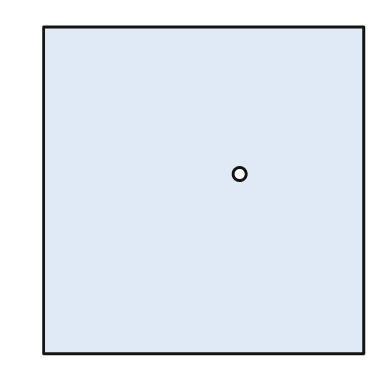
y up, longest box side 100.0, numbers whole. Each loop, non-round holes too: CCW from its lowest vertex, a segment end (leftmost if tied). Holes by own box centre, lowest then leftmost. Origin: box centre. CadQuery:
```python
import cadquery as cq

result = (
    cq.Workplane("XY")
    .moveTo(-49.0, -50.0)
    .lineTo(49.0, -50.0)
    .lineTo(49.0, 50.0)
    .lineTo(-49.0, 50.0)
    .close()
    .moveTo(11.0, 5.0)
    .circle(2.0)
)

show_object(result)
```